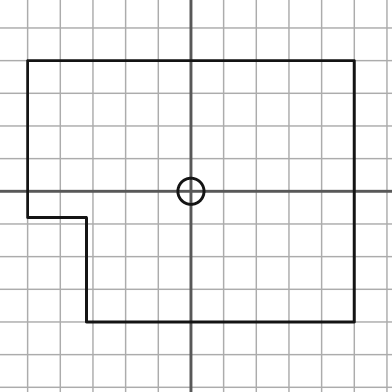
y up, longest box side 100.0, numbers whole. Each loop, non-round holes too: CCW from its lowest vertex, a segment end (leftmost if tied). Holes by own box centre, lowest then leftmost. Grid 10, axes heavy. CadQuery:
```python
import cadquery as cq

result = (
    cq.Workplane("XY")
    .moveTo(-32.0, -40.0)
    .lineTo(50.0, -40.0)
    .lineTo(50.0, 40.0)
    .lineTo(-50.0, 40.0)
    .lineTo(-50.0, -8.0)
    .lineTo(-32.0, -8.0)
    .close()
    .moveTo(0.0, 0.0)
    .circle(4.0)
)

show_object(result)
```